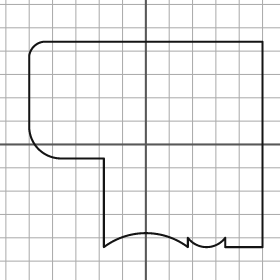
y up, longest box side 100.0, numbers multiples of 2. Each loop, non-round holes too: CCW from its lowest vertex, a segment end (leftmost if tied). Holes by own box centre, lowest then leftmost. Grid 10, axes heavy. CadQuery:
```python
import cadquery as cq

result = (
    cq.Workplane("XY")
    .moveTo(-18.0, -44.0)
    .threePointArc((0.0, -38.0), (18.0, -44.0))
    .lineTo(18.0, -40.0)
    .threePointArc((26.0, -44.0), (34.0, -40.0))
    .lineTo(34.0, -44.0)
    .lineTo(50.0, -44.0)
    .lineTo(50.0, 44.0)
    .lineTo(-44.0, 44.0)
    .threePointArc((-48.0, 42.0), (-50.0, 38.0))
    .lineTo(-50.0, 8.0)
    .threePointArc((-46.0, -2.0), (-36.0, -6.0))
    .lineTo(-18.0, -6.0)
    .close()
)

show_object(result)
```